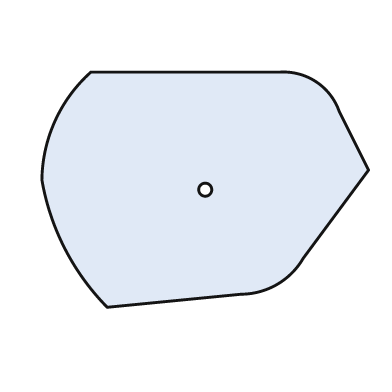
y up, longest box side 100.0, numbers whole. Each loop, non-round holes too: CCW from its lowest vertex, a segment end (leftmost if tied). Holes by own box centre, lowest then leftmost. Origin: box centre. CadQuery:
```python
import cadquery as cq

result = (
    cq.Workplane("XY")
    .moveTo(-30.0, -36.0)
    .lineTo(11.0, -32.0)
    .threePointArc((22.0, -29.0), (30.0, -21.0))
    .lineTo(50.0, 6.0)
    .lineTo(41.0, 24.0)
    .threePointArc((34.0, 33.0), (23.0, 36.0))
    .lineTo(-35.0, 36.0)
    .threePointArc((-46.0, 21.0), (-50.0, 3.0))
    .threePointArc((-43.0, -18.0), (-30.0, -36.0))
    .close()
    .moveTo(0.0, 0.0)
    .circle(2.0)
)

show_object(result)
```